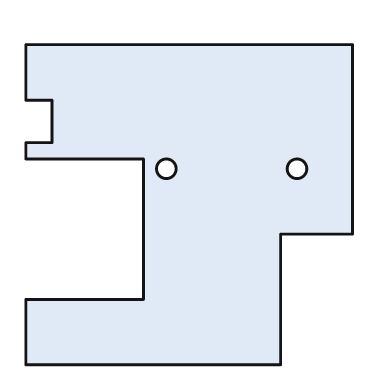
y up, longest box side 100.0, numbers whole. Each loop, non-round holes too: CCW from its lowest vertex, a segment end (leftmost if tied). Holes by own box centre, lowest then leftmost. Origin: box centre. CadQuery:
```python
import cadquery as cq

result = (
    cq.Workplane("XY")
    .moveTo(-50.0, -49.0)
    .lineTo(28.0, -49.0)
    .lineTo(28.0, -9.0)
    .lineTo(50.0, -9.0)
    .lineTo(50.0, 49.0)
    .lineTo(-50.0, 49.0)
    .lineTo(-50.0, 32.0)
    .lineTo(-42.0, 32.0)
    .lineTo(-42.0, 19.0)
    .lineTo(-50.0, 19.0)
    .lineTo(-50.0, 14.0)
    .lineTo(-14.0, 14.0)
    .lineTo(-14.0, -29.0)
    .lineTo(-50.0, -29.0)
    .close()
    .moveTo(-7.0, 11.0)
    .circle(3.0)
    .moveTo(33.0, 11.0)
    .circle(3.0)
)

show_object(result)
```